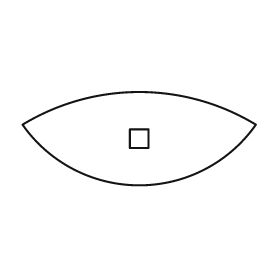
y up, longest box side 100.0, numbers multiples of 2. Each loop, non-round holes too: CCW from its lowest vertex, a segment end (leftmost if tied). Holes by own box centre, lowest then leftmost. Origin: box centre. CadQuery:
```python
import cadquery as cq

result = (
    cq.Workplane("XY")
    .moveTo(-50.0, 6.0)
    .threePointArc((0.0, -20.0), (50.0, 6.0))
    .threePointArc((0.0, 20.0), (-50.0, 6.0))
    .close()
    .moveTo(-4.0, -4.0)
    .lineTo(4.0, -4.0)
    .lineTo(4.0, 4.0)
    .lineTo(-4.0, 4.0)
    .close()
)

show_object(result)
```